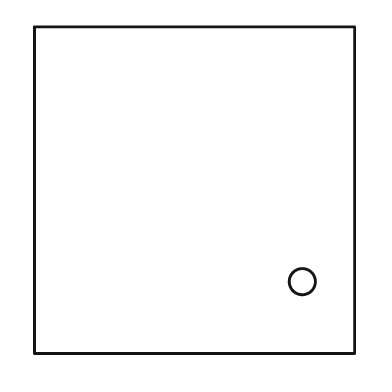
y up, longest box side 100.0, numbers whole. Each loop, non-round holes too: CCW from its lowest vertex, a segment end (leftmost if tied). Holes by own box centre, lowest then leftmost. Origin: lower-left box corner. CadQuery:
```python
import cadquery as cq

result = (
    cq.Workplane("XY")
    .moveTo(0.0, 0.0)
    .lineTo(98.0, 0.0)
    .lineTo(98.0, 100.0)
    .lineTo(0.0, 100.0)
    .close()
    .moveTo(82.0, 22.0)
    .circle(4.0)
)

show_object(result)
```